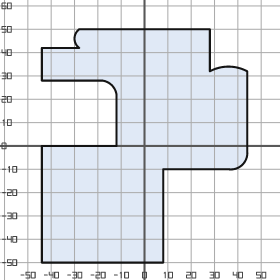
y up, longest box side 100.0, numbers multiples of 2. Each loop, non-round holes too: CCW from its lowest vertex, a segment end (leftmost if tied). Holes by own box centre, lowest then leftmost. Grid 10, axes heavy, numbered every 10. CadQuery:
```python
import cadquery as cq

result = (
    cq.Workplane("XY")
    .moveTo(-44.0, -50.0)
    .lineTo(8.0, -50.0)
    .lineTo(8.0, -10.0)
    .lineTo(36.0, -10.0)
    .threePointArc((42.0, -8.0), (44.0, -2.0))
    .lineTo(44.0, 32.0)
    .threePointArc((36.0, 34.0), (28.0, 32.0))
    .lineTo(28.0, 50.0)
    .lineTo(-28.0, 50.0)
    .threePointArc((-30.0, 46.0), (-28.0, 42.0))
    .lineTo(-44.0, 42.0)
    .lineTo(-44.0, 28.0)
    .lineTo(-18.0, 28.0)
    .threePointArc((-14.0, 26.0), (-12.0, 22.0))
    .lineTo(-12.0, 0.0)
    .lineTo(-44.0, 0.0)
    .close()
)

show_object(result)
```